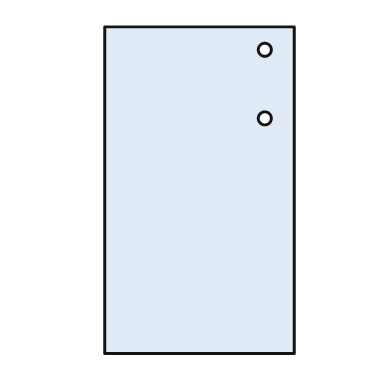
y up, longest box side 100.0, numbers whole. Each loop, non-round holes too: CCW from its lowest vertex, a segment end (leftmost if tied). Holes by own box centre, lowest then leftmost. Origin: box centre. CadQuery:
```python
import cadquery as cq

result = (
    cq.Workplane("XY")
    .moveTo(-29.0, -50.0)
    .lineTo(29.0, -50.0)
    .lineTo(29.0, 50.0)
    .lineTo(-29.0, 50.0)
    .close()
    .moveTo(20.0, 22.0)
    .circle(2.0)
    .moveTo(20.0, 43.0)
    .circle(2.0)
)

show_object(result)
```